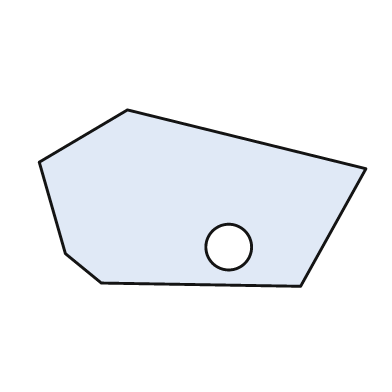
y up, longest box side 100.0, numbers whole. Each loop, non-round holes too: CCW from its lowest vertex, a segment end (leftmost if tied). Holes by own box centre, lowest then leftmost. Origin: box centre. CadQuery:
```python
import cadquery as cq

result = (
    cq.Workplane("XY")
    .moveTo(30.0, -27.0)
    .lineTo(50.0, 9.0)
    .lineTo(-23.0, 27.0)
    .lineTo(-50.0, 11.0)
    .lineTo(-42.0, -17.0)
    .lineTo(-31.0, -26.0)
    .close()
    .moveTo(8.0, -15.0)
    .circle(7.0)
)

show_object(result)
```